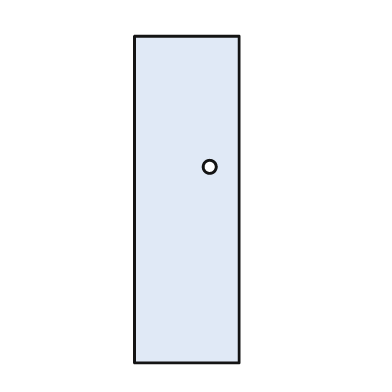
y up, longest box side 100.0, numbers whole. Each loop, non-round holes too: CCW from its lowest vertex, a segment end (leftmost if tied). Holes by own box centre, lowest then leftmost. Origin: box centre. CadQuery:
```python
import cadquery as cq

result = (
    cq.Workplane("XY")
    .moveTo(-16.0, -50.0)
    .lineTo(16.0, -50.0)
    .lineTo(16.0, 50.0)
    .lineTo(-16.0, 50.0)
    .close()
    .moveTo(7.0, 10.0)
    .circle(2.0)
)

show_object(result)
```